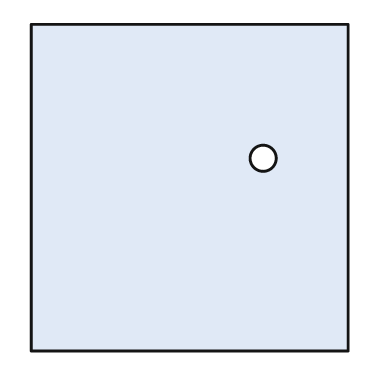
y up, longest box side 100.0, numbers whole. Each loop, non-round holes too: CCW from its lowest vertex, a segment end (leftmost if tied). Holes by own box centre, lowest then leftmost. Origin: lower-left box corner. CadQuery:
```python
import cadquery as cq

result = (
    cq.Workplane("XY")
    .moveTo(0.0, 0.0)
    .lineTo(97.0, 0.0)
    .lineTo(97.0, 100.0)
    .lineTo(0.0, 100.0)
    .close()
    .moveTo(71.0, 59.0)
    .circle(4.0)
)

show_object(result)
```